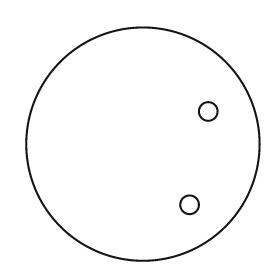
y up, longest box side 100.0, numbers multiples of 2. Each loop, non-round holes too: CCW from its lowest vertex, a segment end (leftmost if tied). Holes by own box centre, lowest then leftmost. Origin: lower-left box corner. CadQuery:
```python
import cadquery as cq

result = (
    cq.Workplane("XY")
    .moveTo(50.0, 50.0)
    .circle(50.0)
    .moveTo(70.0, 24.0)
    .circle(4.0)
    .moveTo(78.0, 64.0)
    .circle(4.0)
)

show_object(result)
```